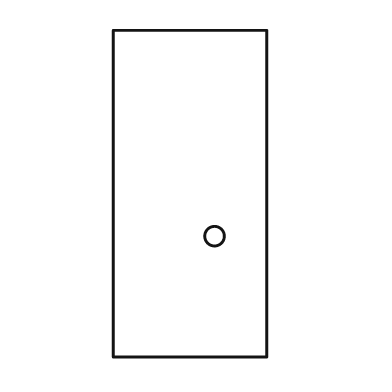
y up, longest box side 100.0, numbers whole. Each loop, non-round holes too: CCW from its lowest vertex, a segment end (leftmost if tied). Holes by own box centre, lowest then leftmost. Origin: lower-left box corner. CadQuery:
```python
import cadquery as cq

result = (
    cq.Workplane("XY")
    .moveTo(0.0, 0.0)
    .lineTo(47.0, 0.0)
    .lineTo(47.0, 100.0)
    .lineTo(0.0, 100.0)
    .close()
    .moveTo(31.0, 37.0)
    .circle(3.0)
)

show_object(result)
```